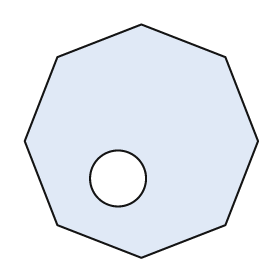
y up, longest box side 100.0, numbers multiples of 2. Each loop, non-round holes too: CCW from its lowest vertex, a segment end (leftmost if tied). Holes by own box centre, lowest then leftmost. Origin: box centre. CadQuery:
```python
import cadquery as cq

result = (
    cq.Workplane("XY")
    .moveTo(0.0, -50.0)
    .lineTo(36.0, -36.0)
    .lineTo(50.0, 0.0)
    .lineTo(36.0, 36.0)
    .lineTo(0.0, 50.0)
    .lineTo(-36.0, 36.0)
    .lineTo(-50.0, 0.0)
    .lineTo(-36.0, -36.0)
    .close()
    .moveTo(-10.0, -16.0)
    .circle(12.0)
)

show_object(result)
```